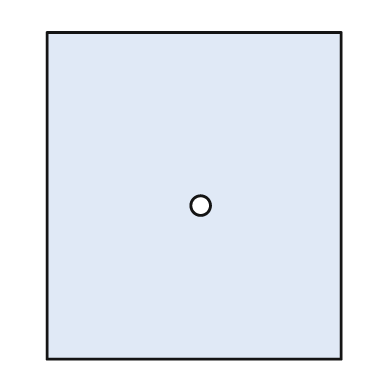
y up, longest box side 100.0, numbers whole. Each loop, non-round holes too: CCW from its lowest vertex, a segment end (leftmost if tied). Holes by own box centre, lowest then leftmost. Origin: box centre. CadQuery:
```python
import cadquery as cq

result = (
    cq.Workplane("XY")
    .moveTo(-45.0, -50.0)
    .lineTo(45.0, -50.0)
    .lineTo(45.0, 50.0)
    .lineTo(-45.0, 50.0)
    .close()
    .moveTo(2.0, -3.0)
    .circle(3.0)
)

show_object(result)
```